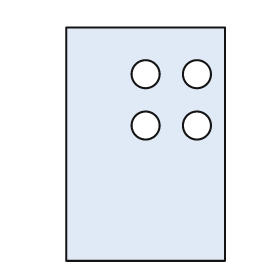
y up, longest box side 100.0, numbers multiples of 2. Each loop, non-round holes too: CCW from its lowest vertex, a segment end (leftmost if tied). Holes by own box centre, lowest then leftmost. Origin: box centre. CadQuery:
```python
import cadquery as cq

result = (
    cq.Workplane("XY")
    .moveTo(-34.0, -50.0)
    .lineTo(34.0, -50.0)
    .lineTo(34.0, 50.0)
    .lineTo(-34.0, 50.0)
    .close()
    .moveTo(0.0, 8.0)
    .circle(6.0)
    .moveTo(22.0, 8.0)
    .circle(6.0)
    .moveTo(0.0, 30.0)
    .circle(6.0)
    .moveTo(22.0, 30.0)
    .circle(6.0)
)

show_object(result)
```